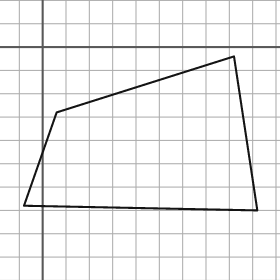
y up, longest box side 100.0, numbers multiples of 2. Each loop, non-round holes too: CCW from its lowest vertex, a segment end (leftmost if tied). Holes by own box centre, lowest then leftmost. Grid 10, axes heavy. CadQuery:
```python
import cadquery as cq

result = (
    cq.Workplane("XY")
    .moveTo(92.0, -70.0)
    .lineTo(82.0, -4.0)
    .lineTo(6.0, -28.0)
    .lineTo(-8.0, -68.0)
    .close()
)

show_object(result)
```